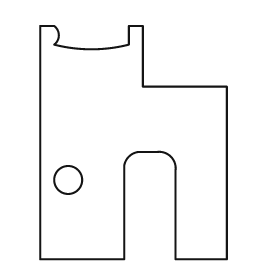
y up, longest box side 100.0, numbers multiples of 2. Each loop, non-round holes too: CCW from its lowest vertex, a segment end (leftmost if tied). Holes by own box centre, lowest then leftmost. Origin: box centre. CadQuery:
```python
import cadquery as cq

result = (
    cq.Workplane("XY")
    .moveTo(-40.0, -50.0)
    .lineTo(-4.0, -50.0)
    .lineTo(-4.0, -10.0)
    .threePointArc((-2.0, -6.0), (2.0, -4.0))
    .lineTo(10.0, -4.0)
    .threePointArc((16.0, -6.0), (18.0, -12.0))
    .lineTo(18.0, -50.0)
    .lineTo(40.0, -50.0)
    .lineTo(40.0, 24.0)
    .lineTo(4.0, 24.0)
    .lineTo(4.0, 50.0)
    .lineTo(-2.0, 50.0)
    .lineTo(-2.0, 42.0)
    .threePointArc((-18.0, 40.0), (-34.0, 42.0))
    .threePointArc((-32.0, 46.0), (-34.0, 50.0))
    .lineTo(-40.0, 50.0)
    .close()
    .moveTo(-28.0, -16.0)
    .circle(6.0)
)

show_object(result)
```